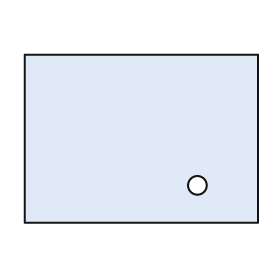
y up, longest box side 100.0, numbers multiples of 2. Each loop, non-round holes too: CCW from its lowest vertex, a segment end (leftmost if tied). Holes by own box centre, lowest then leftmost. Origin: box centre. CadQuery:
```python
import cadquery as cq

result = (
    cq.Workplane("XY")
    .moveTo(-50.0, -36.0)
    .lineTo(50.0, -36.0)
    .lineTo(50.0, 36.0)
    .lineTo(-50.0, 36.0)
    .close()
    .moveTo(24.0, -20.0)
    .circle(4.0)
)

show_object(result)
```